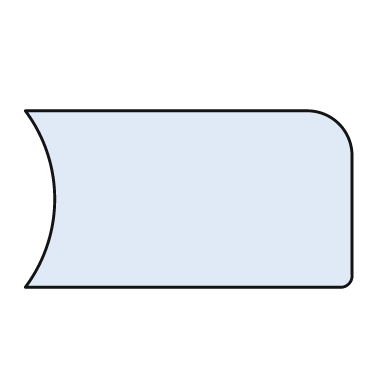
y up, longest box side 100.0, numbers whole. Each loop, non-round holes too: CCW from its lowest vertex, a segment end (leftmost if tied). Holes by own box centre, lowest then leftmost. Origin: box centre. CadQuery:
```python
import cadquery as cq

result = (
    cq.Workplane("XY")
    .moveTo(-50.0, -27.0)
    .lineTo(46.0, -27.0)
    .threePointArc((49.0, -26.0), (50.0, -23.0))
    .lineTo(50.0, 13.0)
    .threePointArc((46.0, 23.0), (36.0, 27.0))
    .lineTo(-50.0, 27.0)
    .threePointArc((-41.0, 0.0), (-50.0, -27.0))
    .close()
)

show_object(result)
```